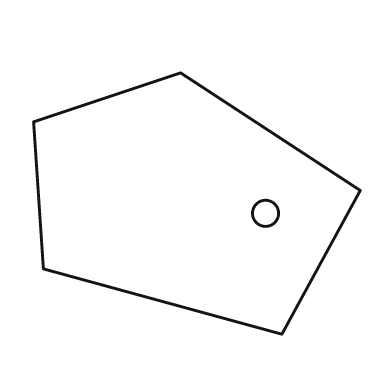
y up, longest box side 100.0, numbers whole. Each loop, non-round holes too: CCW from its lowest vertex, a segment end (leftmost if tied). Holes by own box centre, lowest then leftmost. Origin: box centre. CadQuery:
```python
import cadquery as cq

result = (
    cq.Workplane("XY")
    .moveTo(26.0, -40.0)
    .lineTo(50.0, 4.0)
    .lineTo(-5.0, 40.0)
    .lineTo(-50.0, 25.0)
    .lineTo(-47.0, -20.0)
    .close()
    .moveTo(21.0, -3.0)
    .circle(4.0)
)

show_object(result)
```